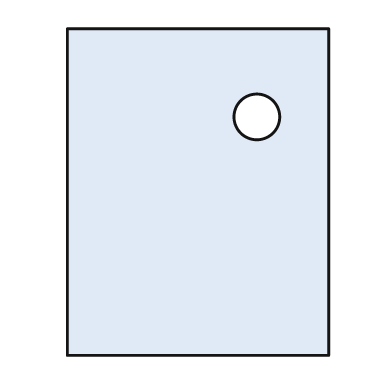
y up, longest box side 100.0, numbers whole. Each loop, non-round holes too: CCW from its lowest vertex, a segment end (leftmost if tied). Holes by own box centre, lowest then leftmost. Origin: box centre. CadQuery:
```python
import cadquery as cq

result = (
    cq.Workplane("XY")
    .moveTo(-40.0, -50.0)
    .lineTo(40.0, -50.0)
    .lineTo(40.0, 50.0)
    .lineTo(-40.0, 50.0)
    .close()
    .moveTo(18.0, 23.0)
    .circle(7.0)
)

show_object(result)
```